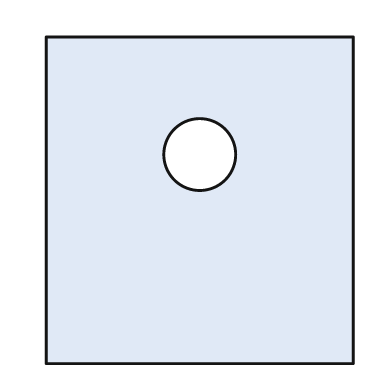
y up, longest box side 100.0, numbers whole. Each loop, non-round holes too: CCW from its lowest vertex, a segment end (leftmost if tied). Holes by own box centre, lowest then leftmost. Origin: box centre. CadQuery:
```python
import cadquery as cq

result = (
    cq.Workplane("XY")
    .moveTo(-47.0, -50.0)
    .lineTo(47.0, -50.0)
    .lineTo(47.0, 50.0)
    .lineTo(-47.0, 50.0)
    .close()
    .moveTo(0.0, 14.0)
    .circle(11.0)
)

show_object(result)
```